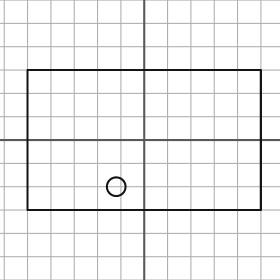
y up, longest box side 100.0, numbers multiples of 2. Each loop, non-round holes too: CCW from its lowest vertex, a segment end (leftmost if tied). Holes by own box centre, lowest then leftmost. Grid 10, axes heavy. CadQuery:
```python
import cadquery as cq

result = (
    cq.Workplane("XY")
    .moveTo(-50.0, -30.0)
    .lineTo(50.0, -30.0)
    .lineTo(50.0, 30.0)
    .lineTo(-50.0, 30.0)
    .close()
    .moveTo(-12.0, -20.0)
    .circle(4.0)
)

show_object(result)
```